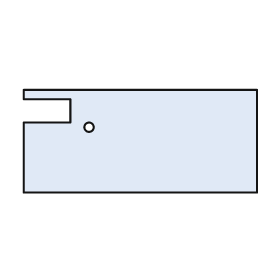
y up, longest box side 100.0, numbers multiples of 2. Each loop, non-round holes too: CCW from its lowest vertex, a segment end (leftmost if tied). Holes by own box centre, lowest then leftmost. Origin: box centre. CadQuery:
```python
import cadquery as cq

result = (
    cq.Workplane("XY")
    .moveTo(-50.0, -22.0)
    .lineTo(50.0, -22.0)
    .lineTo(50.0, 22.0)
    .lineTo(-50.0, 22.0)
    .lineTo(-50.0, 18.0)
    .lineTo(-30.0, 18.0)
    .lineTo(-30.0, 8.0)
    .lineTo(-50.0, 8.0)
    .close()
    .moveTo(-22.0, 6.0)
    .circle(2.0)
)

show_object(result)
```